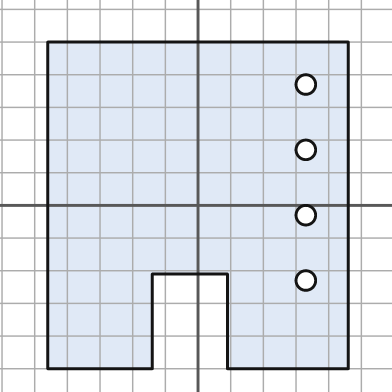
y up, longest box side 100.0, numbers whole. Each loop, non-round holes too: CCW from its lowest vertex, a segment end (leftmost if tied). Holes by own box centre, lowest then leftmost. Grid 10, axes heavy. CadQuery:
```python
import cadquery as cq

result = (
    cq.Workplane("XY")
    .moveTo(-46.0, -50.0)
    .lineTo(-14.0, -50.0)
    .lineTo(-14.0, -21.0)
    .lineTo(9.0, -21.0)
    .lineTo(9.0, -50.0)
    .lineTo(46.0, -50.0)
    .lineTo(46.0, 50.0)
    .lineTo(-46.0, 50.0)
    .close()
    .moveTo(33.0, -23.0)
    .circle(3.0)
    .moveTo(33.0, -3.0)
    .circle(3.0)
    .moveTo(33.0, 17.0)
    .circle(3.0)
    .moveTo(33.0, 37.0)
    .circle(3.0)
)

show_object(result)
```